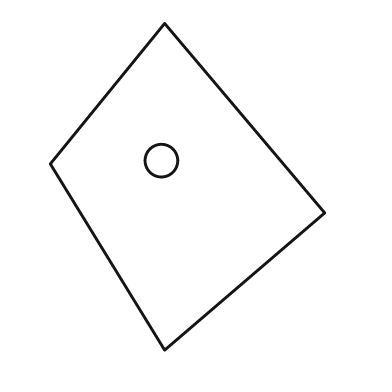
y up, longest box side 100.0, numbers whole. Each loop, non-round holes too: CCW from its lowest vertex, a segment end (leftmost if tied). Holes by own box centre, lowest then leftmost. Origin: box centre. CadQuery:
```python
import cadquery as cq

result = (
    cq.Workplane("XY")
    .moveTo(-7.0, -50.0)
    .lineTo(42.0, -8.0)
    .lineTo(-7.0, 50.0)
    .lineTo(-42.0, 7.0)
    .close()
    .moveTo(-8.0, 8.0)
    .circle(5.0)
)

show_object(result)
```